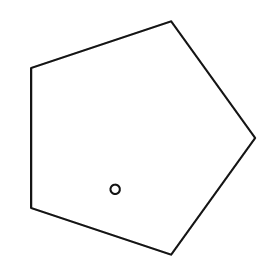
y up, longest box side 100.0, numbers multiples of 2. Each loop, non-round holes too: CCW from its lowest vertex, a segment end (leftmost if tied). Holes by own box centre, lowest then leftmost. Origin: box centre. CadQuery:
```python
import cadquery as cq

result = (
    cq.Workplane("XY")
    .moveTo(12.0, -50.0)
    .lineTo(48.0, 0.0)
    .lineTo(12.0, 50.0)
    .lineTo(-48.0, 30.0)
    .lineTo(-48.0, -30.0)
    .close()
    .moveTo(-12.0, -22.0)
    .circle(2.0)
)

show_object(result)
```